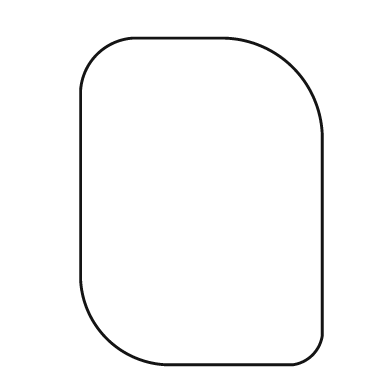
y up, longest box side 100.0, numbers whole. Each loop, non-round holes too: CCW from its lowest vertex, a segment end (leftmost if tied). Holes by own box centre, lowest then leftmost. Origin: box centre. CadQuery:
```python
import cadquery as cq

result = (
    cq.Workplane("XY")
    .moveTo(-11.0, -50.0)
    .lineTo(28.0, -50.0)
    .threePointArc((34.0, -47.0), (37.0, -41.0))
    .lineTo(37.0, 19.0)
    .threePointArc((28.0, 41.0), (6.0, 50.0))
    .lineTo(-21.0, 50.0)
    .threePointArc((-32.0, 45.0), (-37.0, 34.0))
    .lineTo(-37.0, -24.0)
    .threePointArc((-29.0, -42.0), (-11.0, -50.0))
    .close()
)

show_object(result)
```